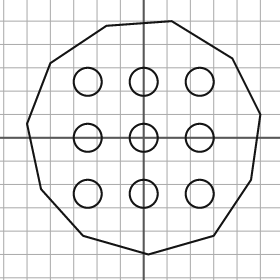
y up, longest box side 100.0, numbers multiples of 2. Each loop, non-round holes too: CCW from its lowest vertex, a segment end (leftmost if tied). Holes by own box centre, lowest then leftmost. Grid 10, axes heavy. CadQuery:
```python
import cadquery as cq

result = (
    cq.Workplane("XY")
    .moveTo(2.0, -50.0)
    .lineTo(30.0, -42.0)
    .lineTo(46.0, -18.0)
    .lineTo(50.0, 10.0)
    .lineTo(38.0, 34.0)
    .lineTo(12.0, 50.0)
    .lineTo(-16.0, 48.0)
    .lineTo(-40.0, 32.0)
    .lineTo(-50.0, 6.0)
    .lineTo(-44.0, -22.0)
    .lineTo(-26.0, -42.0)
    .close()
    .moveTo(-24.0, -24.0)
    .circle(6.0)
    .moveTo(0.0, -24.0)
    .circle(6.0)
    .moveTo(24.0, -24.0)
    .circle(6.0)
    .moveTo(-24.0, 0.0)
    .circle(6.0)
    .moveTo(0.0, 0.0)
    .circle(6.0)
    .moveTo(24.0, 0.0)
    .circle(6.0)
    .moveTo(-24.0, 24.0)
    .circle(6.0)
    .moveTo(0.0, 24.0)
    .circle(6.0)
    .moveTo(24.0, 24.0)
    .circle(6.0)
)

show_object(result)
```